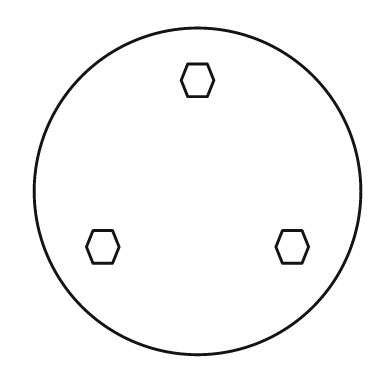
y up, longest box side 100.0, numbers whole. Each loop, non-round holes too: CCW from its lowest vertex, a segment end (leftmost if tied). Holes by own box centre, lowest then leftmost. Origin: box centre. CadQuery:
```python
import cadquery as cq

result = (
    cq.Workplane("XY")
    .moveTo(0.0, 0.0)
    .circle(50.0)
    .moveTo(-32.0, -22.0)
    .lineTo(-26.0, -22.0)
    .lineTo(-24.0, -17.0)
    .lineTo(-26.0, -12.0)
    .lineTo(-32.0, -12.0)
    .lineTo(-34.0, -17.0)
    .close()
    .moveTo(26.0, -22.0)
    .lineTo(32.0, -22.0)
    .lineTo(34.0, -17.0)
    .lineTo(32.0, -12.0)
    .lineTo(26.0, -12.0)
    .lineTo(24.0, -17.0)
    .close()
    .moveTo(-3.0, 29.0)
    .lineTo(3.0, 29.0)
    .lineTo(5.0, 34.0)
    .lineTo(3.0, 39.0)
    .lineTo(-3.0, 39.0)
    .lineTo(-5.0, 34.0)
    .close()
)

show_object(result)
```